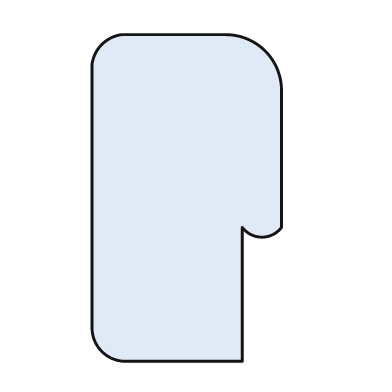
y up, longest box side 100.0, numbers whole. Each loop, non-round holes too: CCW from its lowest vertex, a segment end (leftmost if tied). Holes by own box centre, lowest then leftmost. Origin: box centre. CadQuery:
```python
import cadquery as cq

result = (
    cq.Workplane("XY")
    .moveTo(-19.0, -50.0)
    .lineTo(17.0, -50.0)
    .lineTo(17.0, -9.0)
    .threePointArc((23.0, -12.0), (29.0, -9.0))
    .lineTo(29.0, 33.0)
    .threePointArc((24.0, 45.0), (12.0, 50.0))
    .lineTo(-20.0, 50.0)
    .threePointArc((-26.0, 47.0), (-29.0, 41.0))
    .lineTo(-29.0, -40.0)
    .threePointArc((-26.0, -47.0), (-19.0, -50.0))
    .close()
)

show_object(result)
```